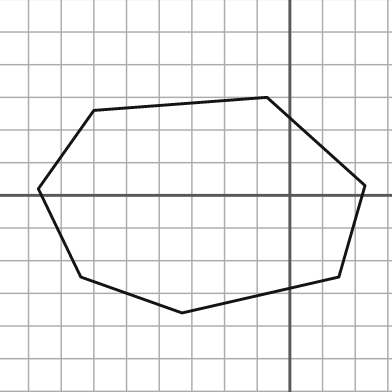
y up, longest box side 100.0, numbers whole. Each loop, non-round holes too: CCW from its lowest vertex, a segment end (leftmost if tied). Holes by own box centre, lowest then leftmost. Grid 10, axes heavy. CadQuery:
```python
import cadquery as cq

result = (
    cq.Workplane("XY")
    .moveTo(-33.0, -36.0)
    .lineTo(15.0, -25.0)
    .lineTo(23.0, 3.0)
    .lineTo(-7.0, 30.0)
    .lineTo(-60.0, 26.0)
    .lineTo(-77.0, 2.0)
    .lineTo(-64.0, -25.0)
    .close()
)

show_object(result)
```